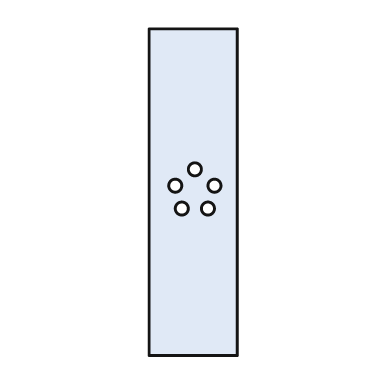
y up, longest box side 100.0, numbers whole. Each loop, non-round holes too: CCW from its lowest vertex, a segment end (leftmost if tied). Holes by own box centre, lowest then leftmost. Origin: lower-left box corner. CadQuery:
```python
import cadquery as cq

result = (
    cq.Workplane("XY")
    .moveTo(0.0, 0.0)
    .lineTo(27.0, 0.0)
    .lineTo(27.0, 100.0)
    .lineTo(0.0, 100.0)
    .close()
    .moveTo(10.0, 45.0)
    .circle(2.0)
    .moveTo(18.0, 45.0)
    .circle(2.0)
    .moveTo(8.0, 52.0)
    .circle(2.0)
    .moveTo(20.0, 52.0)
    .circle(2.0)
    .moveTo(14.0, 57.0)
    .circle(2.0)
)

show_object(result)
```